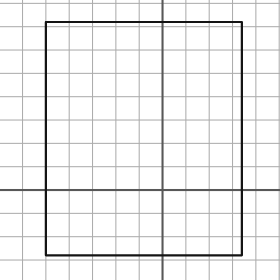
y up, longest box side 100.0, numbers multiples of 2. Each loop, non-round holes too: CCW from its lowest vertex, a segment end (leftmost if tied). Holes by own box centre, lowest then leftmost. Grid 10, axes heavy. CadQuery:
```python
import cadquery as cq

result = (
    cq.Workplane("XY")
    .moveTo(-50.0, -28.0)
    .lineTo(34.0, -28.0)
    .lineTo(34.0, 72.0)
    .lineTo(-50.0, 72.0)
    .close()
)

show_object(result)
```